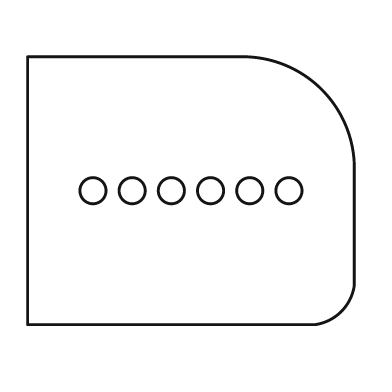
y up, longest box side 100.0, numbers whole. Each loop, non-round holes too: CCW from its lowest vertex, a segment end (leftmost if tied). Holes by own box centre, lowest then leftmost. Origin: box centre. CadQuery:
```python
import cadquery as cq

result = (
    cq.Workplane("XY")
    .moveTo(-50.0, -41.0)
    .lineTo(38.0, -41.0)
    .threePointArc((46.0, -37.0), (50.0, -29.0))
    .lineTo(50.0, 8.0)
    .threePointArc((40.0, 31.0), (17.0, 41.0))
    .lineTo(-50.0, 41.0)
    .close()
    .moveTo(-30.0, 0.0)
    .circle(4.0)
    .moveTo(-18.0, 0.0)
    .circle(4.0)
    .moveTo(-6.0, 0.0)
    .circle(4.0)
    .moveTo(6.0, 0.0)
    .circle(4.0)
    .moveTo(18.0, 0.0)
    .circle(4.0)
    .moveTo(30.0, 0.0)
    .circle(4.0)
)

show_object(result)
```